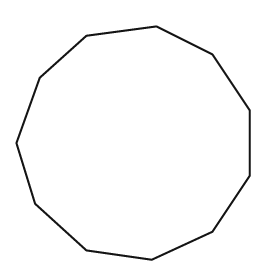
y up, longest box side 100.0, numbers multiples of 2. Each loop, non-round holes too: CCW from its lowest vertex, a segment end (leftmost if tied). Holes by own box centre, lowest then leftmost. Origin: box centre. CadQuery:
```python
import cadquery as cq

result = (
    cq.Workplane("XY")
    .moveTo(8.0, -50.0)
    .lineTo(34.0, -38.0)
    .lineTo(50.0, -14.0)
    .lineTo(50.0, 14.0)
    .lineTo(34.0, 38.0)
    .lineTo(10.0, 50.0)
    .lineTo(-20.0, 46.0)
    .lineTo(-40.0, 28.0)
    .lineTo(-50.0, 0.0)
    .lineTo(-42.0, -26.0)
    .lineTo(-20.0, -46.0)
    .close()
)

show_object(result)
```